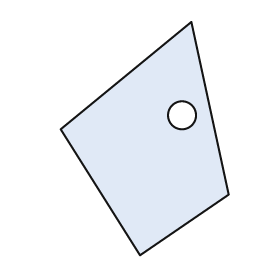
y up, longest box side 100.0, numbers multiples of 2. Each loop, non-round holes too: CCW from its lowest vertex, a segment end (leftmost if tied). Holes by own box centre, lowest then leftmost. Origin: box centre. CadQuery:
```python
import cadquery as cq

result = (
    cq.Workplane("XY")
    .moveTo(-2.0, -50.0)
    .lineTo(36.0, -24.0)
    .lineTo(20.0, 50.0)
    .lineTo(-36.0, 4.0)
    .close()
    .moveTo(16.0, 10.0)
    .circle(6.0)
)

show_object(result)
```